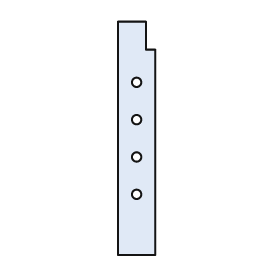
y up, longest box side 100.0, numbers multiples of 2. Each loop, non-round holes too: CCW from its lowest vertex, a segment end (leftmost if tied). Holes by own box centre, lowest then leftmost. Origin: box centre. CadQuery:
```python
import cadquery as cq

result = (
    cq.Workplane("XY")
    .moveTo(-8.0, -50.0)
    .lineTo(8.0, -50.0)
    .lineTo(8.0, 38.0)
    .lineTo(4.0, 38.0)
    .lineTo(4.0, 50.0)
    .lineTo(-8.0, 50.0)
    .close()
    .moveTo(0.0, -24.0)
    .circle(2.0)
    .moveTo(0.0, -8.0)
    .circle(2.0)
    .moveTo(0.0, 8.0)
    .circle(2.0)
    .moveTo(0.0, 24.0)
    .circle(2.0)
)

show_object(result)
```